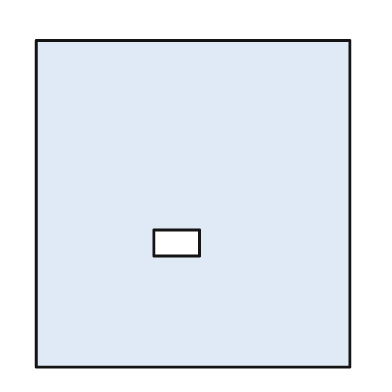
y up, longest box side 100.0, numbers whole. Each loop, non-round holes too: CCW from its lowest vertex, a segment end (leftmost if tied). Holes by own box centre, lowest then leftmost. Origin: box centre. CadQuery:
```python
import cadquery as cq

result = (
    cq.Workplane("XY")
    .moveTo(-48.0, -50.0)
    .lineTo(48.0, -50.0)
    .lineTo(48.0, 50.0)
    .lineTo(-48.0, 50.0)
    .close()
    .moveTo(-12.0, -16.0)
    .lineTo(2.0, -16.0)
    .lineTo(2.0, -8.0)
    .lineTo(-12.0, -8.0)
    .close()
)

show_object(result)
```